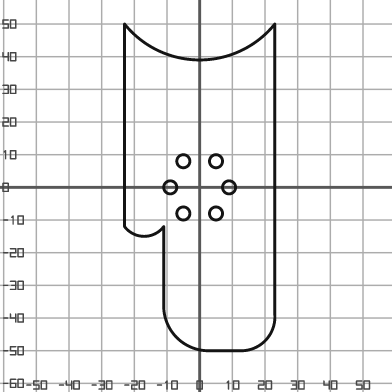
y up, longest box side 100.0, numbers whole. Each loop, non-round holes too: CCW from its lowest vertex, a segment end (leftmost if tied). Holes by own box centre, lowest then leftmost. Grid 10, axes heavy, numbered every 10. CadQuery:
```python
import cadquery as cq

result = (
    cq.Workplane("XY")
    .moveTo(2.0, -50.0)
    .lineTo(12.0, -50.0)
    .threePointArc((20.0, -47.0), (23.0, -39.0))
    .lineTo(23.0, 50.0)
    .threePointArc((0.0, 39.0), (-23.0, 50.0))
    .lineTo(-23.0, -12.0)
    .threePointArc((-17.0, -15.0), (-11.0, -12.0))
    .lineTo(-11.0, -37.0)
    .threePointArc((-7.0, -46.0), (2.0, -50.0))
    .close()
    .moveTo(-5.0, -8.0)
    .circle(2.0)
    .moveTo(5.0, -8.0)
    .circle(2.0)
    .moveTo(-9.0, 0.0)
    .circle(2.0)
    .moveTo(9.0, 0.0)
    .circle(2.0)
    .moveTo(-5.0, 8.0)
    .circle(2.0)
    .moveTo(5.0, 8.0)
    .circle(2.0)
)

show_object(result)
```